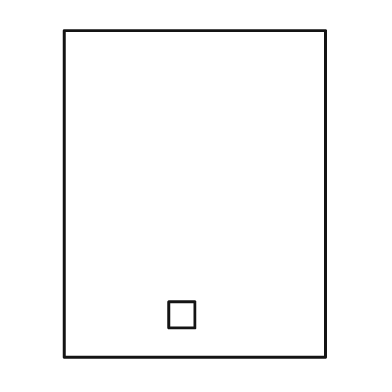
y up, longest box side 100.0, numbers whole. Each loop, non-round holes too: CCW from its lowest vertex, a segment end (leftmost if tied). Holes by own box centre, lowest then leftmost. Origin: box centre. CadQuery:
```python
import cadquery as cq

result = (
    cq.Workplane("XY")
    .moveTo(-40.0, -50.0)
    .lineTo(40.0, -50.0)
    .lineTo(40.0, 50.0)
    .lineTo(-40.0, 50.0)
    .close()
    .moveTo(-8.0, -41.0)
    .lineTo(0.0, -41.0)
    .lineTo(0.0, -33.0)
    .lineTo(-8.0, -33.0)
    .close()
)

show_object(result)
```